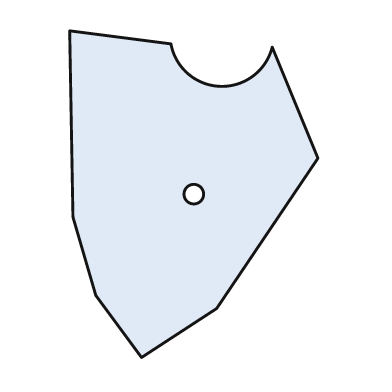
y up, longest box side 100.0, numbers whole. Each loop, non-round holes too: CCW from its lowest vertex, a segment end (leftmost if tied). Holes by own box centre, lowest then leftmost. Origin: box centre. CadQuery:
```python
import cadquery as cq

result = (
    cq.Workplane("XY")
    .moveTo(-16.0, -50.0)
    .lineTo(7.0, -35.0)
    .lineTo(38.0, 11.0)
    .lineTo(24.0, 45.0)
    .threePointArc((8.0, 33.0), (-7.0, 46.0))
    .lineTo(-38.0, 50.0)
    .lineTo(-37.0, -7.0)
    .lineTo(-30.0, -31.0)
    .close()
    .moveTo(0.0, 0.0)
    .circle(3.0)
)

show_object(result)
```